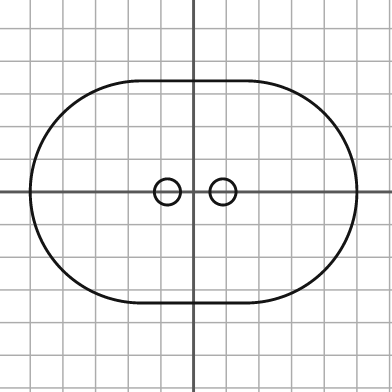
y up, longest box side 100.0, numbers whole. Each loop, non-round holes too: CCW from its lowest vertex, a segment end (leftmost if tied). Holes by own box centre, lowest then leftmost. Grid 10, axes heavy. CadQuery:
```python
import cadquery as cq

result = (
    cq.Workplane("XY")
    .moveTo(-16.0, -34.0)
    .lineTo(16.0, -34.0)
    .threePointArc((50.0, 0.0), (16.0, 34.0))
    .lineTo(-16.0, 34.0)
    .threePointArc((-50.0, 0.0), (-16.0, -34.0))
    .close()
    .moveTo(-8.0, 0.0)
    .circle(4.0)
    .moveTo(9.0, 0.0)
    .circle(4.0)
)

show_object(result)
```